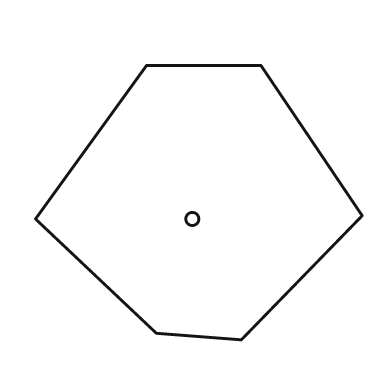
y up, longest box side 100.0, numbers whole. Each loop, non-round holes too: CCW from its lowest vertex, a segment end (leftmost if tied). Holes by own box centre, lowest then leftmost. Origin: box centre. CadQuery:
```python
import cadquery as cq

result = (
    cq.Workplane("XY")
    .moveTo(13.0, -42.0)
    .lineTo(50.0, -4.0)
    .lineTo(19.0, 42.0)
    .lineTo(-16.0, 42.0)
    .lineTo(-50.0, -5.0)
    .lineTo(-13.0, -40.0)
    .close()
    .moveTo(-2.0, -5.0)
    .circle(2.0)
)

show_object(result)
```